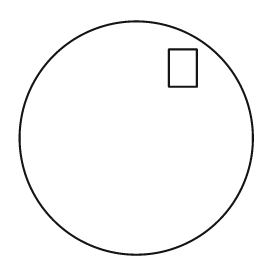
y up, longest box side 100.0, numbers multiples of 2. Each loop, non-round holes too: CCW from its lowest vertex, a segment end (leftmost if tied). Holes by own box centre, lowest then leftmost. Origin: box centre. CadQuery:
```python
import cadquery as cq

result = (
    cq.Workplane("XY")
    .moveTo(0.0, 0.0)
    .circle(50.0)
    .moveTo(14.0, 22.0)
    .lineTo(26.0, 22.0)
    .lineTo(26.0, 38.0)
    .lineTo(14.0, 38.0)
    .close()
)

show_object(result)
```